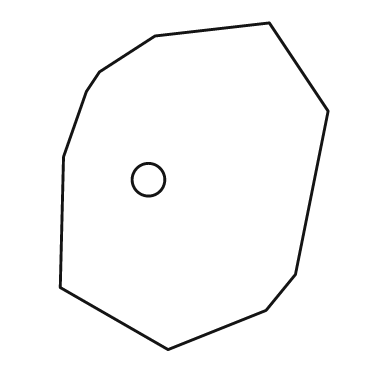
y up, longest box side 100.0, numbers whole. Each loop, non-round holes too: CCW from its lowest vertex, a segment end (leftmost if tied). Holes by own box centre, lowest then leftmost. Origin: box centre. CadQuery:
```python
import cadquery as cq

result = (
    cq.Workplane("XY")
    .moveTo(-8.0, -50.0)
    .lineTo(22.0, -38.0)
    .lineTo(31.0, -27.0)
    .lineTo(41.0, 23.0)
    .lineTo(23.0, 50.0)
    .lineTo(-12.0, 46.0)
    .lineTo(-29.0, 35.0)
    .lineTo(-33.0, 29.0)
    .lineTo(-40.0, 9.0)
    .lineTo(-41.0, -31.0)
    .close()
    .moveTo(-14.0, 2.0)
    .circle(5.0)
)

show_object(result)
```